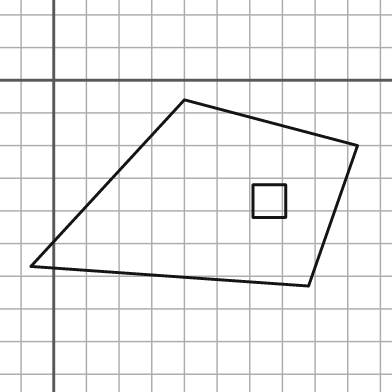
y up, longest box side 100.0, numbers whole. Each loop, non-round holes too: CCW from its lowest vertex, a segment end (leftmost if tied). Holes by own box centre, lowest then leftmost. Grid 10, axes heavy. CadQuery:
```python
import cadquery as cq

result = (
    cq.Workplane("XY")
    .moveTo(78.0, -63.0)
    .lineTo(93.0, -20.0)
    .lineTo(40.0, -6.0)
    .lineTo(-7.0, -57.0)
    .close()
    .moveTo(61.0, -42.0)
    .lineTo(71.0, -42.0)
    .lineTo(71.0, -32.0)
    .lineTo(61.0, -32.0)
    .close()
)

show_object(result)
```